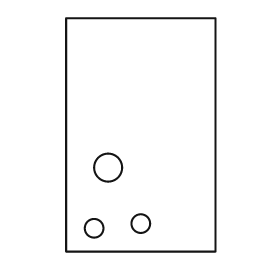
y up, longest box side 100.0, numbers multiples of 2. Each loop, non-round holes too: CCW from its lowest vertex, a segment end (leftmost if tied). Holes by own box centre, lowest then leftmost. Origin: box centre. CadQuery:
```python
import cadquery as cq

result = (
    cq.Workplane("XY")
    .moveTo(-32.0, -50.0)
    .lineTo(32.0, -50.0)
    .lineTo(32.0, 50.0)
    .lineTo(-32.0, 50.0)
    .close()
    .moveTo(-20.0, -40.0)
    .circle(4.0)
    .moveTo(0.0, -38.0)
    .circle(4.0)
    .moveTo(-14.0, -14.0)
    .circle(6.0)
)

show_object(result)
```